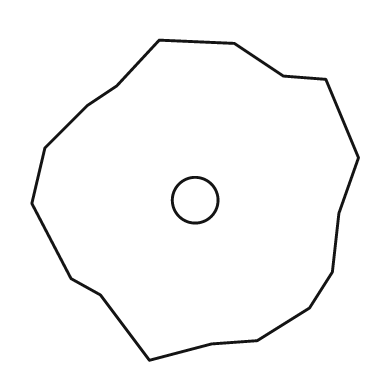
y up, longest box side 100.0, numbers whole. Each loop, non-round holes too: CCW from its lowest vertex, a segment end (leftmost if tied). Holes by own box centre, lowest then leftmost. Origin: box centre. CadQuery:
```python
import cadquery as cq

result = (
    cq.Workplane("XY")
    .moveTo(-14.0, -49.0)
    .lineTo(5.0, -44.0)
    .lineTo(19.0, -43.0)
    .lineTo(35.0, -33.0)
    .lineTo(42.0, -22.0)
    .lineTo(44.0, -4.0)
    .lineTo(50.0, 13.0)
    .lineTo(40.0, 37.0)
    .lineTo(27.0, 38.0)
    .lineTo(12.0, 48.0)
    .lineTo(-11.0, 49.0)
    .lineTo(-24.0, 35.0)
    .lineTo(-33.0, 29.0)
    .lineTo(-46.0, 16.0)
    .lineTo(-50.0, -1.0)
    .lineTo(-38.0, -24.0)
    .lineTo(-29.0, -29.0)
    .close()
    .moveTo(0.0, 0.0)
    .circle(7.0)
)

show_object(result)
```